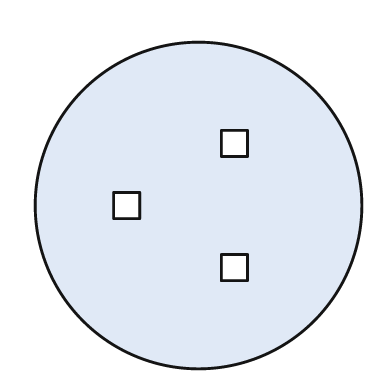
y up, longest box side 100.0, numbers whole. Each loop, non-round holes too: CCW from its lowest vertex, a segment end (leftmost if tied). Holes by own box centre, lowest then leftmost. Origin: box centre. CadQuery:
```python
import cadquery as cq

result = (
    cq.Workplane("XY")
    .moveTo(0.0, 0.0)
    .circle(50.0)
    .moveTo(7.0, -23.0)
    .lineTo(15.0, -23.0)
    .lineTo(15.0, -15.0)
    .lineTo(7.0, -15.0)
    .close()
    .moveTo(-26.0, -4.0)
    .lineTo(-18.0, -4.0)
    .lineTo(-18.0, 4.0)
    .lineTo(-26.0, 4.0)
    .close()
    .moveTo(7.0, 15.0)
    .lineTo(15.0, 15.0)
    .lineTo(15.0, 23.0)
    .lineTo(7.0, 23.0)
    .close()
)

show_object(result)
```